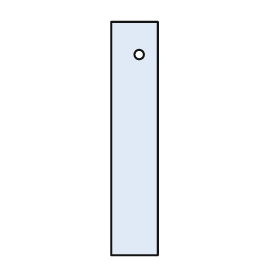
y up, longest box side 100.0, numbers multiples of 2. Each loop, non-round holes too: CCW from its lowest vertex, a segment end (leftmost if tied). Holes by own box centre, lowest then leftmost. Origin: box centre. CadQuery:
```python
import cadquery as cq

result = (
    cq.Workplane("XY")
    .moveTo(-10.0, -50.0)
    .lineTo(10.0, -50.0)
    .lineTo(10.0, 50.0)
    .lineTo(-10.0, 50.0)
    .close()
    .moveTo(2.0, 36.0)
    .circle(2.0)
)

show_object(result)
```